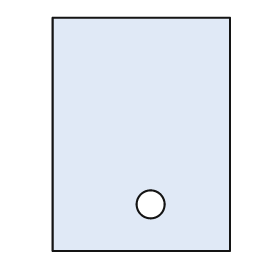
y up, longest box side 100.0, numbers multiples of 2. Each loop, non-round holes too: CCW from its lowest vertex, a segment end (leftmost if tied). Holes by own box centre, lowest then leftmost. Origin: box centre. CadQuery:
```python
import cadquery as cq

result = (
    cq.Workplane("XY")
    .moveTo(-38.0, -50.0)
    .lineTo(38.0, -50.0)
    .lineTo(38.0, 50.0)
    .lineTo(-38.0, 50.0)
    .close()
    .moveTo(4.0, -30.0)
    .circle(6.0)
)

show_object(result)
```